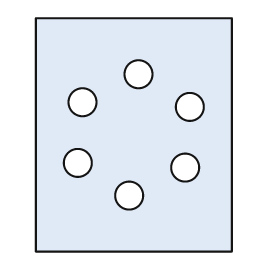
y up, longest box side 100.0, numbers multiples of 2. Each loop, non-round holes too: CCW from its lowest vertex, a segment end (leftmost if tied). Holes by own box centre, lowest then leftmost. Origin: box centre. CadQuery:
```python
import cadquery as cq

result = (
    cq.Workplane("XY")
    .moveTo(-42.0, -50.0)
    .lineTo(42.0, -50.0)
    .lineTo(42.0, 50.0)
    .lineTo(-42.0, 50.0)
    .close()
    .moveTo(-2.0, -26.0)
    .circle(6.0)
    .moveTo(22.0, -14.0)
    .circle(6.0)
    .moveTo(-24.0, -12.0)
    .circle(6.0)
    .moveTo(24.0, 12.0)
    .circle(6.0)
    .moveTo(-22.0, 14.0)
    .circle(6.0)
    .moveTo(2.0, 26.0)
    .circle(6.0)
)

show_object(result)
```